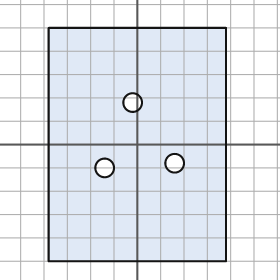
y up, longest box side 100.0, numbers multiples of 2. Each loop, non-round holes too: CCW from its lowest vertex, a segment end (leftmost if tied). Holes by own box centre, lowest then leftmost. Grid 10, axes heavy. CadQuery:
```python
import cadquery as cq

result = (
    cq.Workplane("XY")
    .moveTo(-38.0, -50.0)
    .lineTo(38.0, -50.0)
    .lineTo(38.0, 50.0)
    .lineTo(-38.0, 50.0)
    .close()
    .moveTo(-14.0, -10.0)
    .circle(4.0)
    .moveTo(16.0, -8.0)
    .circle(4.0)
    .moveTo(-2.0, 18.0)
    .circle(4.0)
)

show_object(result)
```